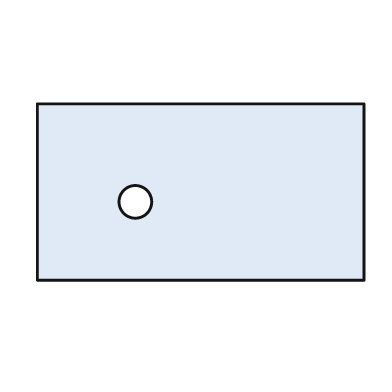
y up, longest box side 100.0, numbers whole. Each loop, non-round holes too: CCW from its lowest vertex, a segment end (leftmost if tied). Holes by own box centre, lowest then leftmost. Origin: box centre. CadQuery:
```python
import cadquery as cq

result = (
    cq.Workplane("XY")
    .moveTo(-50.0, -27.0)
    .lineTo(50.0, -27.0)
    .lineTo(50.0, 27.0)
    .lineTo(-50.0, 27.0)
    .close()
    .moveTo(-20.0, -3.0)
    .circle(5.0)
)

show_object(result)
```